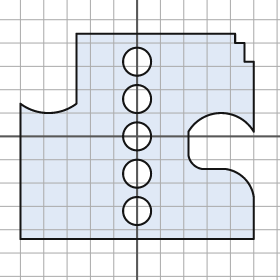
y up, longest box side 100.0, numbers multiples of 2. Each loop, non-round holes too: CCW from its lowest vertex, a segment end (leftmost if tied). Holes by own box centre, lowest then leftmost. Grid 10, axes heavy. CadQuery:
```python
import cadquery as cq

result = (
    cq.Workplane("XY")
    .moveTo(-50.0, -44.0)
    .lineTo(50.0, -44.0)
    .lineTo(50.0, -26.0)
    .threePointArc((46.0, -18.0), (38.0, -14.0))
    .lineTo(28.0, -14.0)
    .threePointArc((24.0, -12.0), (22.0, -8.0))
    .lineTo(22.0, 2.0)
    .threePointArc((36.0, 10.0), (50.0, 2.0))
    .lineTo(50.0, 32.0)
    .lineTo(46.0, 32.0)
    .lineTo(46.0, 40.0)
    .lineTo(42.0, 40.0)
    .lineTo(42.0, 44.0)
    .lineTo(-26.0, 44.0)
    .lineTo(-26.0, 14.0)
    .threePointArc((-38.0, 10.0), (-50.0, 14.0))
    .close()
    .moveTo(0.0, -32.0)
    .circle(6.0)
    .moveTo(0.0, -16.0)
    .circle(6.0)
    .moveTo(0.0, 0.0)
    .circle(6.0)
    .moveTo(0.0, 16.0)
    .circle(6.0)
    .moveTo(0.0, 32.0)
    .circle(6.0)
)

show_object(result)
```